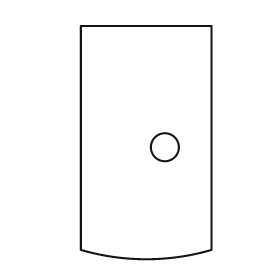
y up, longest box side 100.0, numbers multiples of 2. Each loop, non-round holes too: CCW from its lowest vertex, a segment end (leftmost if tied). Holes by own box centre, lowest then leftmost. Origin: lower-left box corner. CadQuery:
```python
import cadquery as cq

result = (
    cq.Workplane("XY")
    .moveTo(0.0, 4.0)
    .threePointArc((28.0, 0.0), (56.0, 4.0))
    .lineTo(56.0, 100.0)
    .lineTo(0.0, 100.0)
    .close()
    .moveTo(36.0, 48.0)
    .circle(6.0)
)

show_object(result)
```